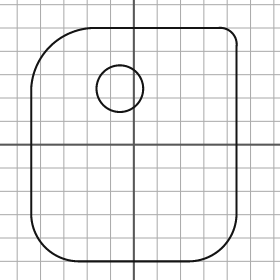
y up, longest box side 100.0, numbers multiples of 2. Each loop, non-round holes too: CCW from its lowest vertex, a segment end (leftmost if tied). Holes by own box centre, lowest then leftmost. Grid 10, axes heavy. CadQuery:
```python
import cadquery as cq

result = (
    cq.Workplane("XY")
    .moveTo(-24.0, -50.0)
    .lineTo(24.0, -50.0)
    .threePointArc((38.0, -44.0), (44.0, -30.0))
    .lineTo(44.0, 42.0)
    .threePointArc((42.0, 48.0), (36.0, 50.0))
    .lineTo(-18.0, 50.0)
    .threePointArc((-36.0, 42.0), (-44.0, 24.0))
    .lineTo(-44.0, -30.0)
    .threePointArc((-38.0, -44.0), (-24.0, -50.0))
    .close()
    .moveTo(-6.0, 24.0)
    .circle(10.0)
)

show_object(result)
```